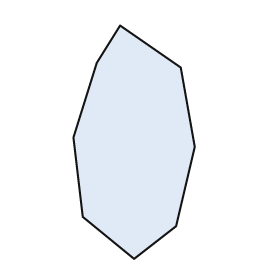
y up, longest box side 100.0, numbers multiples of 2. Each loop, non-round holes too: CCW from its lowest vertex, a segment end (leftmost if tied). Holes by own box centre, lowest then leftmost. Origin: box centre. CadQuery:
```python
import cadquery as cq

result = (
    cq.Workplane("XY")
    .moveTo(0.0, -50.0)
    .lineTo(18.0, -36.0)
    .lineTo(26.0, -2.0)
    .lineTo(20.0, 32.0)
    .lineTo(-6.0, 50.0)
    .lineTo(-16.0, 34.0)
    .lineTo(-26.0, 2.0)
    .lineTo(-22.0, -32.0)
    .close()
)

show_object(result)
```